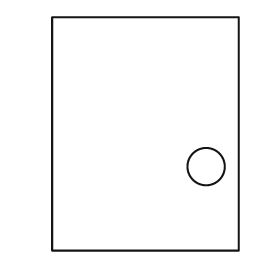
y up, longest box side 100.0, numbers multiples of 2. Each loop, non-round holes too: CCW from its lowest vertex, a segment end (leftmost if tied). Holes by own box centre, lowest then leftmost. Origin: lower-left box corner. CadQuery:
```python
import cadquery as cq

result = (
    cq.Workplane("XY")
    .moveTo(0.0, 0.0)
    .lineTo(80.0, 0.0)
    .lineTo(80.0, 100.0)
    .lineTo(0.0, 100.0)
    .close()
    .moveTo(66.0, 36.0)
    .circle(8.0)
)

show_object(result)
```